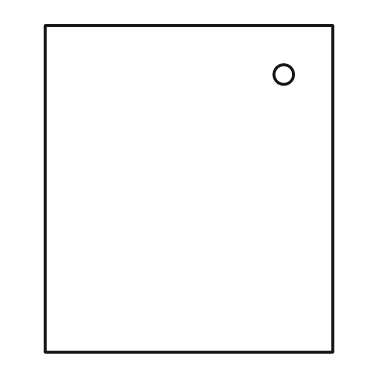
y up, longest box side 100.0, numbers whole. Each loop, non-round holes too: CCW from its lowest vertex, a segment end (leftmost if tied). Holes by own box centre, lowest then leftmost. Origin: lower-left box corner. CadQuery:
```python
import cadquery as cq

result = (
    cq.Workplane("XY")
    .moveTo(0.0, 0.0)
    .lineTo(88.0, 0.0)
    .lineTo(88.0, 100.0)
    .lineTo(0.0, 100.0)
    .close()
    .moveTo(73.0, 85.0)
    .circle(3.0)
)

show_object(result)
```